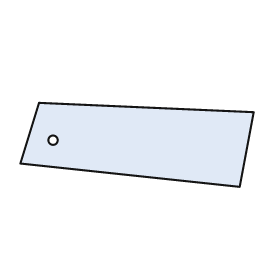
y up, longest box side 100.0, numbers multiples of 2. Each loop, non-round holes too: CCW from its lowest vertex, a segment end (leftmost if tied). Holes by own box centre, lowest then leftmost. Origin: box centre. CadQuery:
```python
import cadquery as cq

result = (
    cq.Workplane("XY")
    .moveTo(44.0, -18.0)
    .lineTo(50.0, 14.0)
    .lineTo(-42.0, 18.0)
    .lineTo(-50.0, -8.0)
    .close()
    .moveTo(-36.0, 2.0)
    .circle(2.0)
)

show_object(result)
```